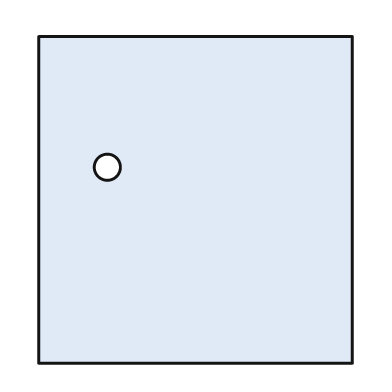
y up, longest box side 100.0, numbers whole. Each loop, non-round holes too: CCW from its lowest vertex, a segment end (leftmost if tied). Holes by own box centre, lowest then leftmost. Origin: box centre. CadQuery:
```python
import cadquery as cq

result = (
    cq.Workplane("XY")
    .moveTo(-48.0, -50.0)
    .lineTo(48.0, -50.0)
    .lineTo(48.0, 50.0)
    .lineTo(-48.0, 50.0)
    .close()
    .moveTo(-27.0, 10.0)
    .circle(4.0)
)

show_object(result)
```